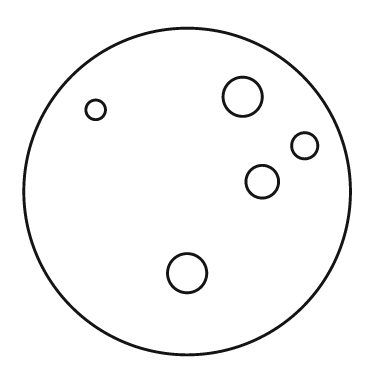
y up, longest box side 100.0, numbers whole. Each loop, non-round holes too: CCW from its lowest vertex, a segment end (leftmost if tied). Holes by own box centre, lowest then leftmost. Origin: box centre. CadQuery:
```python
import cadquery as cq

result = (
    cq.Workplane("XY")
    .moveTo(0.0, 0.0)
    .circle(50.0)
    .moveTo(0.0, -25.0)
    .circle(6.0)
    .moveTo(23.0, 3.0)
    .circle(5.0)
    .moveTo(36.0, 14.0)
    .circle(4.0)
    .moveTo(-28.0, 25.0)
    .circle(3.0)
    .moveTo(17.0, 29.0)
    .circle(6.0)
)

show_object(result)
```